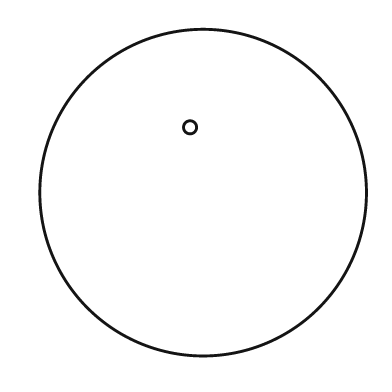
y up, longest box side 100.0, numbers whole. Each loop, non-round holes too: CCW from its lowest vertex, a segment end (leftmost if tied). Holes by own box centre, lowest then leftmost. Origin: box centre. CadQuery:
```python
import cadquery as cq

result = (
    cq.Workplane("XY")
    .moveTo(0.0, 0.0)
    .circle(50.0)
    .moveTo(-4.0, 20.0)
    .circle(2.0)
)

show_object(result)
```